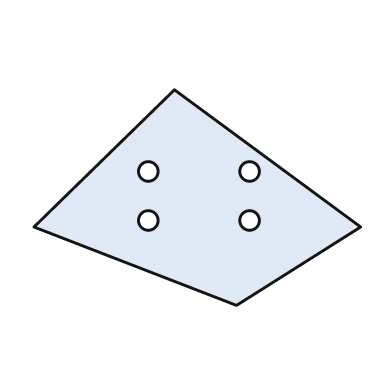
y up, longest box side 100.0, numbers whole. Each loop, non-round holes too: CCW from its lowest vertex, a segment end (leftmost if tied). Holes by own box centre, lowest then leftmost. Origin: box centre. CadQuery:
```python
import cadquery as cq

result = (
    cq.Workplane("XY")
    .moveTo(12.0, -33.0)
    .lineTo(50.0, -9.0)
    .lineTo(-7.0, 33.0)
    .lineTo(-50.0, -9.0)
    .close()
    .moveTo(-15.0, -7.0)
    .circle(3.0)
    .moveTo(16.0, -7.0)
    .circle(3.0)
    .moveTo(-15.0, 8.0)
    .circle(3.0)
    .moveTo(16.0, 8.0)
    .circle(3.0)
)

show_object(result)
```